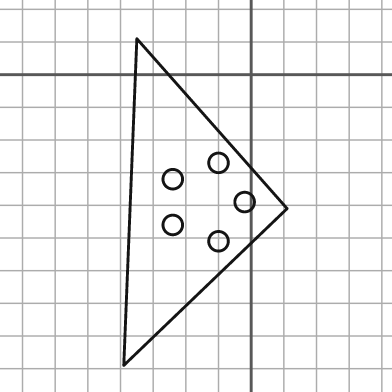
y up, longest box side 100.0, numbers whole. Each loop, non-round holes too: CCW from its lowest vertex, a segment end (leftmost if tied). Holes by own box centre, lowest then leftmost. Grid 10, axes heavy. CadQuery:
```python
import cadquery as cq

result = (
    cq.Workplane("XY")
    .moveTo(-39.0, -89.0)
    .lineTo(11.0, -41.0)
    .lineTo(-35.0, 11.0)
    .close()
    .moveTo(-10.0, -51.0)
    .circle(3.0)
    .moveTo(-24.0, -46.0)
    .circle(3.0)
    .moveTo(-2.0, -39.0)
    .circle(3.0)
    .moveTo(-24.0, -32.0)
    .circle(3.0)
    .moveTo(-10.0, -27.0)
    .circle(3.0)
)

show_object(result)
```